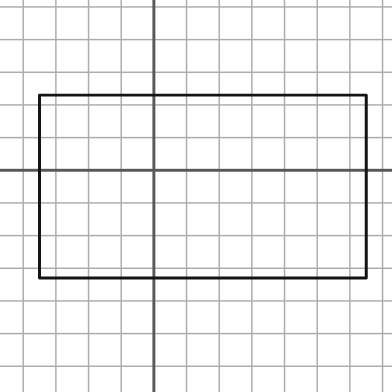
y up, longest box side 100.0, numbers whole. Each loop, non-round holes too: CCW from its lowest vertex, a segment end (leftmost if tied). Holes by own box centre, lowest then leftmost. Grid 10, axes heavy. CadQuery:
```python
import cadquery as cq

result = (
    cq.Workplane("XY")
    .moveTo(-35.0, -33.0)
    .lineTo(65.0, -33.0)
    .lineTo(65.0, 23.0)
    .lineTo(-35.0, 23.0)
    .close()
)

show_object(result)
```